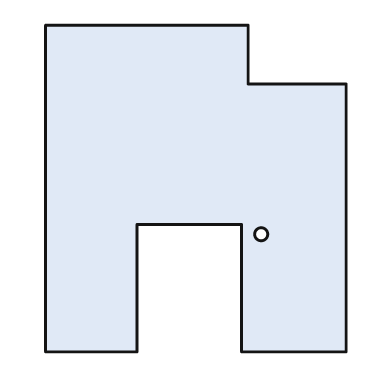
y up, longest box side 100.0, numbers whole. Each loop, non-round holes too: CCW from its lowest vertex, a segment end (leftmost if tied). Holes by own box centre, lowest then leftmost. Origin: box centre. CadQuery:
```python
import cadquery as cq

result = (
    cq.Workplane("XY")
    .moveTo(-46.0, -50.0)
    .lineTo(-18.0, -50.0)
    .lineTo(-18.0, -11.0)
    .lineTo(14.0, -11.0)
    .lineTo(14.0, -50.0)
    .lineTo(46.0, -50.0)
    .lineTo(46.0, 32.0)
    .lineTo(16.0, 32.0)
    .lineTo(16.0, 50.0)
    .lineTo(-46.0, 50.0)
    .close()
    .moveTo(20.0, -14.0)
    .circle(2.0)
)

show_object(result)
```